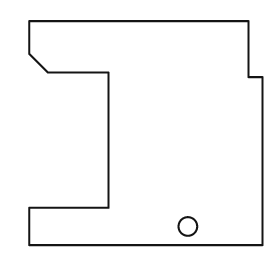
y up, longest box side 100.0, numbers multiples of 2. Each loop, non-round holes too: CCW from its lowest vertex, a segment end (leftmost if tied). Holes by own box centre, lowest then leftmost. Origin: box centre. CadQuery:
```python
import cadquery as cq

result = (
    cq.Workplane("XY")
    .moveTo(-50.0, -48.0)
    .lineTo(50.0, -48.0)
    .lineTo(50.0, 24.0)
    .lineTo(44.0, 24.0)
    .lineTo(44.0, 48.0)
    .lineTo(-50.0, 48.0)
    .lineTo(-50.0, 34.0)
    .lineTo(-42.0, 26.0)
    .lineTo(-16.0, 26.0)
    .lineTo(-16.0, -32.0)
    .lineTo(-50.0, -32.0)
    .close()
    .moveTo(18.0, -40.0)
    .circle(4.0)
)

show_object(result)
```